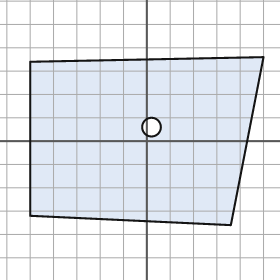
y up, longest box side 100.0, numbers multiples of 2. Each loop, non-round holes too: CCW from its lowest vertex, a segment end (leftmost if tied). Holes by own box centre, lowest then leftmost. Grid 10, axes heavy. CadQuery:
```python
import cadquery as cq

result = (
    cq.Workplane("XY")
    .moveTo(36.0, -36.0)
    .lineTo(50.0, 36.0)
    .lineTo(-50.0, 34.0)
    .lineTo(-50.0, -32.0)
    .close()
    .moveTo(2.0, 6.0)
    .circle(4.0)
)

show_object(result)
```